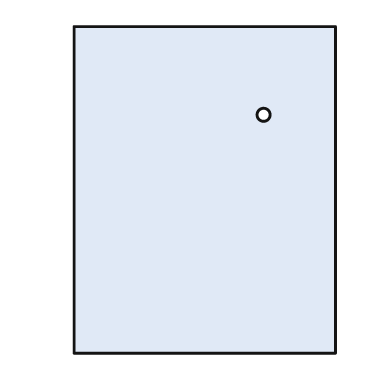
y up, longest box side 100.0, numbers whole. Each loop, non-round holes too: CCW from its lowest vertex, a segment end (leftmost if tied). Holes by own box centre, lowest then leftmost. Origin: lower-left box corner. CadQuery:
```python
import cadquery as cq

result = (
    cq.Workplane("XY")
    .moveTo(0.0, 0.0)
    .lineTo(80.0, 0.0)
    .lineTo(80.0, 100.0)
    .lineTo(0.0, 100.0)
    .close()
    .moveTo(58.0, 73.0)
    .circle(2.0)
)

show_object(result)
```